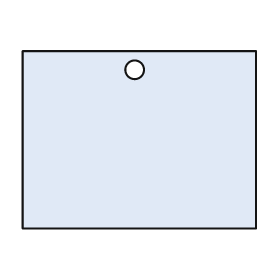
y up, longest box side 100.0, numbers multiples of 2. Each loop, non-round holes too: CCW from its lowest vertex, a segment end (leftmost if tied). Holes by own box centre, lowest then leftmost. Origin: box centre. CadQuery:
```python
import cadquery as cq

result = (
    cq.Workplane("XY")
    .moveTo(-50.0, -38.0)
    .lineTo(50.0, -38.0)
    .lineTo(50.0, 38.0)
    .lineTo(-50.0, 38.0)
    .close()
    .moveTo(-2.0, 30.0)
    .circle(4.0)
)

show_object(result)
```